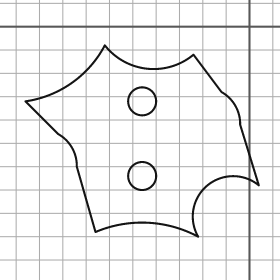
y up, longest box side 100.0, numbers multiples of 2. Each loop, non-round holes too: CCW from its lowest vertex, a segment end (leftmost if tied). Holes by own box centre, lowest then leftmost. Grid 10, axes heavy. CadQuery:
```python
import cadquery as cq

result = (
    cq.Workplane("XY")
    .moveTo(-22.0, -90.0)
    .threePointArc((-18.0, -68.0), (4.0, -68.0))
    .lineTo(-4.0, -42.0)
    .threePointArc((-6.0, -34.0), (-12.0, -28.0))
    .lineTo(-24.0, -12.0)
    .threePointArc((-44.0, -18.0), (-62.0, -8.0))
    .threePointArc((-76.0, -24.0), (-96.0, -32.0))
    .lineTo(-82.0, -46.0)
    .threePointArc((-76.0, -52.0), (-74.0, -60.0))
    .lineTo(-66.0, -88.0)
    .threePointArc((-44.0, -84.0), (-22.0, -90.0))
    .close()
    .moveTo(-46.0, -64.0)
    .circle(6.0)
    .moveTo(-46.0, -32.0)
    .circle(6.0)
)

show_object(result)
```